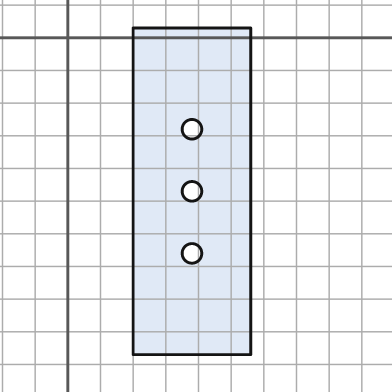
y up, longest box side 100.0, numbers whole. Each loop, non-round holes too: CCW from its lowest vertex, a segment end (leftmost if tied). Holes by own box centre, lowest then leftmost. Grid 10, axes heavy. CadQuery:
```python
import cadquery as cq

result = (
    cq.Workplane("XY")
    .moveTo(20.0, -97.0)
    .lineTo(56.0, -97.0)
    .lineTo(56.0, 3.0)
    .lineTo(20.0, 3.0)
    .close()
    .moveTo(38.0, -66.0)
    .circle(3.0)
    .moveTo(38.0, -47.0)
    .circle(3.0)
    .moveTo(38.0, -28.0)
    .circle(3.0)
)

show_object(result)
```